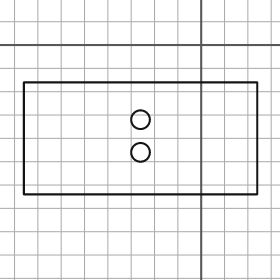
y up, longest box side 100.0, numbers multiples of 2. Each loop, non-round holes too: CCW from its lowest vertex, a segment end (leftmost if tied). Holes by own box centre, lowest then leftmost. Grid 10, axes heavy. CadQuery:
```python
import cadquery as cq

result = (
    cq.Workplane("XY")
    .moveTo(-76.0, -64.0)
    .lineTo(24.0, -64.0)
    .lineTo(24.0, -16.0)
    .lineTo(-76.0, -16.0)
    .close()
    .moveTo(-26.0, -46.0)
    .circle(4.0)
    .moveTo(-26.0, -32.0)
    .circle(4.0)
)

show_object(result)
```